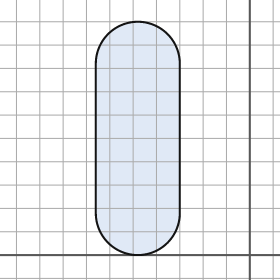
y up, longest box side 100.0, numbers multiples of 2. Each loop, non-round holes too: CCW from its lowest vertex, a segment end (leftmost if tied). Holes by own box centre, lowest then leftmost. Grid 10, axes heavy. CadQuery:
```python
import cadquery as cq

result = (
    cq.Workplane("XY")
    .moveTo(-66.0, 18.0)
    .threePointArc((-48.0, 0.0), (-30.0, 18.0))
    .lineTo(-30.0, 82.0)
    .threePointArc((-48.0, 100.0), (-66.0, 82.0))
    .close()
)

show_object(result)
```